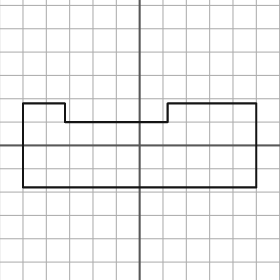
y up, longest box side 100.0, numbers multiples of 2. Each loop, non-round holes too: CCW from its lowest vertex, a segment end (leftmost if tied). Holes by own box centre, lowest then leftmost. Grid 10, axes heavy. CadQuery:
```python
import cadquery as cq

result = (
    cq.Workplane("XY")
    .moveTo(-50.0, -18.0)
    .lineTo(50.0, -18.0)
    .lineTo(50.0, 18.0)
    .lineTo(12.0, 18.0)
    .lineTo(12.0, 10.0)
    .lineTo(-32.0, 10.0)
    .lineTo(-32.0, 18.0)
    .lineTo(-50.0, 18.0)
    .close()
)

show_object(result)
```